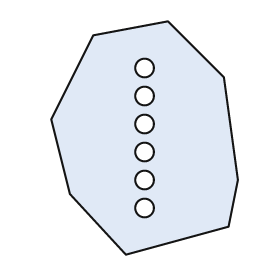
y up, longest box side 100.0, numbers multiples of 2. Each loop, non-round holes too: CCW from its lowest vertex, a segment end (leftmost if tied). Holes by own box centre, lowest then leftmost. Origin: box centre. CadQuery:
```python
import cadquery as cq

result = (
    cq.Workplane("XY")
    .moveTo(-8.0, -50.0)
    .lineTo(36.0, -38.0)
    .lineTo(40.0, -18.0)
    .lineTo(34.0, 26.0)
    .lineTo(10.0, 50.0)
    .lineTo(-22.0, 44.0)
    .lineTo(-40.0, 8.0)
    .lineTo(-32.0, -24.0)
    .close()
    .moveTo(0.0, -30.0)
    .circle(4.0)
    .moveTo(0.0, -18.0)
    .circle(4.0)
    .moveTo(0.0, -6.0)
    .circle(4.0)
    .moveTo(0.0, 6.0)
    .circle(4.0)
    .moveTo(0.0, 18.0)
    .circle(4.0)
    .moveTo(0.0, 30.0)
    .circle(4.0)
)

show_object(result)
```